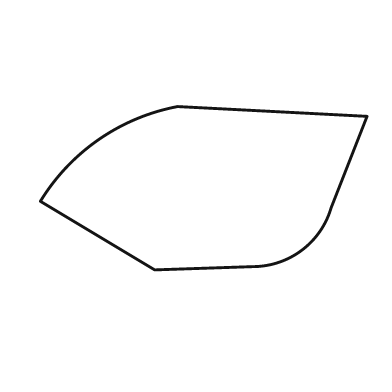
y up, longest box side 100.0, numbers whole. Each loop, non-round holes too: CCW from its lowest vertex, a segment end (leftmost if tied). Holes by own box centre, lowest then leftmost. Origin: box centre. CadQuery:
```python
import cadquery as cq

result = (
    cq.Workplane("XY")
    .moveTo(-15.0, -25.0)
    .lineTo(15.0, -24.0)
    .threePointArc((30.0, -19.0), (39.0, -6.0))
    .lineTo(50.0, 22.0)
    .lineTo(-8.0, 25.0)
    .threePointArc((-32.0, 15.0), (-50.0, -4.0))
    .close()
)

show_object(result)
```